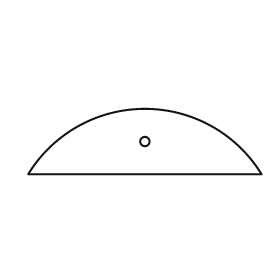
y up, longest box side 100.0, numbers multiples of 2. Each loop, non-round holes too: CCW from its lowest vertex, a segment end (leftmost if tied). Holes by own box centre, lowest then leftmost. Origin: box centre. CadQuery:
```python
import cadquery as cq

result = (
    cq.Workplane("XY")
    .moveTo(-50.0, -14.0)
    .lineTo(50.0, -14.0)
    .threePointArc((0.0, 14.0), (-50.0, -14.0))
    .close()
    .moveTo(0.0, 0.0)
    .circle(2.0)
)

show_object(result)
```